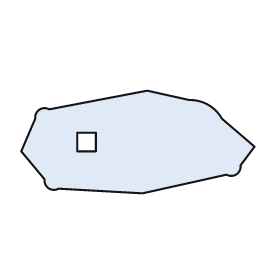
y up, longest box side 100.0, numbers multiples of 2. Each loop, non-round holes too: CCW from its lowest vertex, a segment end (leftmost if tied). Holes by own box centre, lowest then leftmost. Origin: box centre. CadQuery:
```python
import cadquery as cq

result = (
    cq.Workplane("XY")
    .moveTo(2.0, -22.0)
    .lineTo(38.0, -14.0)
    .threePointArc((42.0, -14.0), (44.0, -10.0))
    .lineTo(50.0, -2.0)
    .lineTo(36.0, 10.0)
    .threePointArc((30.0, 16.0), (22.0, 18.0))
    .lineTo(4.0, 22.0)
    .lineTo(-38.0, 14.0)
    .threePointArc((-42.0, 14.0), (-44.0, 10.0))
    .lineTo(-50.0, -4.0)
    .lineTo(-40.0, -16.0)
    .threePointArc((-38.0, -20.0), (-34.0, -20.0))
    .close()
    .moveTo(-26.0, -4.0)
    .lineTo(-18.0, -4.0)
    .lineTo(-18.0, 4.0)
    .lineTo(-26.0, 4.0)
    .close()
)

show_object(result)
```